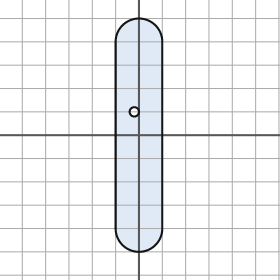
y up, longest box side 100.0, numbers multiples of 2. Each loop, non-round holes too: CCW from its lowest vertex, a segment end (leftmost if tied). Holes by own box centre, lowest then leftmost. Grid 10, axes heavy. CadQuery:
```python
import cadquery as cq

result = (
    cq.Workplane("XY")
    .moveTo(-10.0, -40.0)
    .threePointArc((0.0, -50.0), (10.0, -40.0))
    .lineTo(10.0, 40.0)
    .threePointArc((0.0, 50.0), (-10.0, 40.0))
    .close()
    .moveTo(-2.0, 10.0)
    .circle(2.0)
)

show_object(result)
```